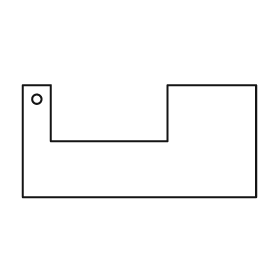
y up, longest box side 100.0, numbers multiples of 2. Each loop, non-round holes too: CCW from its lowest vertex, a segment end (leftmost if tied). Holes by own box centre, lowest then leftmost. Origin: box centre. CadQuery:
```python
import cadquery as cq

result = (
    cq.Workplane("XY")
    .moveTo(-50.0, -24.0)
    .lineTo(50.0, -24.0)
    .lineTo(50.0, 24.0)
    .lineTo(12.0, 24.0)
    .lineTo(12.0, 0.0)
    .lineTo(-38.0, 0.0)
    .lineTo(-38.0, 24.0)
    .lineTo(-50.0, 24.0)
    .close()
    .moveTo(-44.0, 18.0)
    .circle(2.0)
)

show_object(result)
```